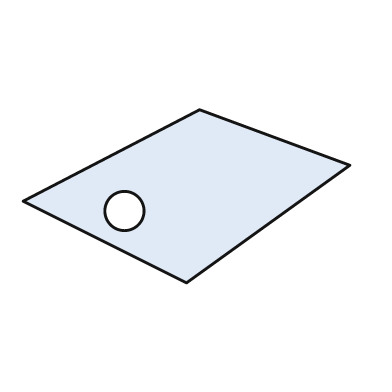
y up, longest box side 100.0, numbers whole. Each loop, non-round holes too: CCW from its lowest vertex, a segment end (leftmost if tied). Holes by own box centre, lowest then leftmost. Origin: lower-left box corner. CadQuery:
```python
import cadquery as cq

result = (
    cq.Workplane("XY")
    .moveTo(50.0, 0.0)
    .lineTo(100.0, 36.0)
    .lineTo(54.0, 53.0)
    .lineTo(0.0, 25.0)
    .close()
    .moveTo(31.0, 22.0)
    .circle(6.0)
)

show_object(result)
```